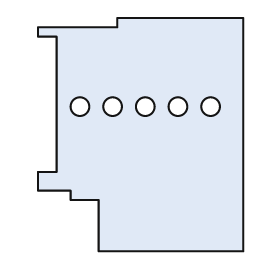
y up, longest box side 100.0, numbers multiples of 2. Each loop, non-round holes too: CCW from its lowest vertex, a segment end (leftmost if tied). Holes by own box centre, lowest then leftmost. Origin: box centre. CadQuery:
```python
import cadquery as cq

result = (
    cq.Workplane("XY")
    .moveTo(-18.0, -50.0)
    .lineTo(44.0, -50.0)
    .lineTo(44.0, 50.0)
    .lineTo(-10.0, 50.0)
    .lineTo(-10.0, 46.0)
    .lineTo(-44.0, 46.0)
    .lineTo(-44.0, 42.0)
    .lineTo(-36.0, 42.0)
    .lineTo(-36.0, -16.0)
    .lineTo(-44.0, -16.0)
    .lineTo(-44.0, -24.0)
    .lineTo(-30.0, -24.0)
    .lineTo(-30.0, -28.0)
    .lineTo(-18.0, -28.0)
    .close()
    .moveTo(-26.0, 12.0)
    .circle(4.0)
    .moveTo(-12.0, 12.0)
    .circle(4.0)
    .moveTo(2.0, 12.0)
    .circle(4.0)
    .moveTo(16.0, 12.0)
    .circle(4.0)
    .moveTo(30.0, 12.0)
    .circle(4.0)
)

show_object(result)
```